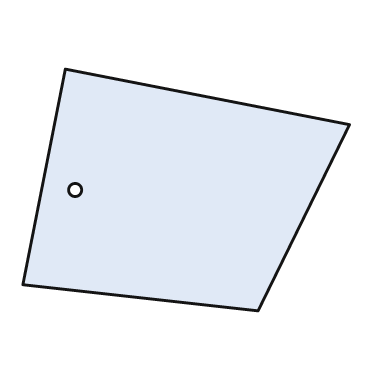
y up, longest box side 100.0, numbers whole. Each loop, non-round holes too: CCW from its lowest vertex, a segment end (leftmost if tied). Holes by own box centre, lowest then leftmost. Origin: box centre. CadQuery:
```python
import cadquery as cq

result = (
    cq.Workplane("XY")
    .moveTo(22.0, -37.0)
    .lineTo(50.0, 20.0)
    .lineTo(-37.0, 37.0)
    .lineTo(-50.0, -29.0)
    .close()
    .moveTo(-34.0, 0.0)
    .circle(2.0)
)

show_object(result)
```